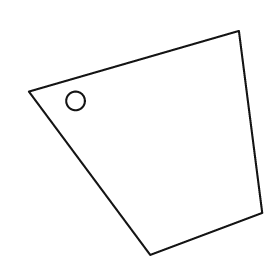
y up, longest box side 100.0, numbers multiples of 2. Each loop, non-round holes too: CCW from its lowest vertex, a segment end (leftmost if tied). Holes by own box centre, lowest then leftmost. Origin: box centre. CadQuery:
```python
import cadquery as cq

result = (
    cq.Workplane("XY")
    .moveTo(2.0, -48.0)
    .lineTo(50.0, -30.0)
    .lineTo(40.0, 48.0)
    .lineTo(-50.0, 22.0)
    .close()
    .moveTo(-30.0, 18.0)
    .circle(4.0)
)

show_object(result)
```